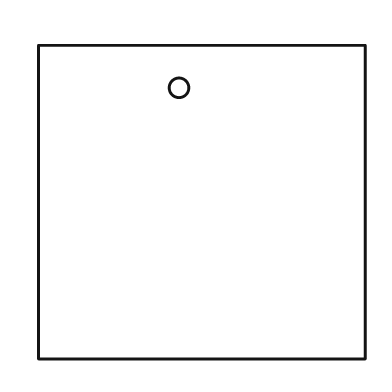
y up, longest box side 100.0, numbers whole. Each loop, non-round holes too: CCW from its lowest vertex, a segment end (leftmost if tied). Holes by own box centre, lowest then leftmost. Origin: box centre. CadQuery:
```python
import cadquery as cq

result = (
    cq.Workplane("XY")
    .moveTo(-50.0, -48.0)
    .lineTo(50.0, -48.0)
    .lineTo(50.0, 48.0)
    .lineTo(-50.0, 48.0)
    .close()
    .moveTo(-7.0, 35.0)
    .circle(3.0)
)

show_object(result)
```